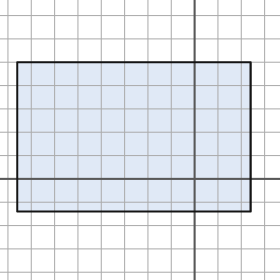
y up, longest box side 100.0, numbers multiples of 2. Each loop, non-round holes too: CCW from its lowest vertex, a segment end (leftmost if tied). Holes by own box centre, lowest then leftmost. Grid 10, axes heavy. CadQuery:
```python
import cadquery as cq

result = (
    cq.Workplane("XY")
    .moveTo(-76.0, -14.0)
    .lineTo(24.0, -14.0)
    .lineTo(24.0, 50.0)
    .lineTo(-76.0, 50.0)
    .close()
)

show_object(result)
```